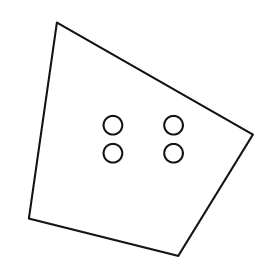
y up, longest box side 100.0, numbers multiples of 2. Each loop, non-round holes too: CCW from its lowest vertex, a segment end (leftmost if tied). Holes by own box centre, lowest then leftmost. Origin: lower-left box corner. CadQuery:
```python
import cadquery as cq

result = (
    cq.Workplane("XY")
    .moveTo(64.0, 0.0)
    .lineTo(96.0, 52.0)
    .lineTo(12.0, 100.0)
    .lineTo(0.0, 16.0)
    .close()
    .moveTo(36.0, 44.0)
    .circle(4.0)
    .moveTo(62.0, 44.0)
    .circle(4.0)
    .moveTo(36.0, 56.0)
    .circle(4.0)
    .moveTo(62.0, 56.0)
    .circle(4.0)
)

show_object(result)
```